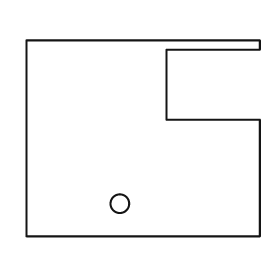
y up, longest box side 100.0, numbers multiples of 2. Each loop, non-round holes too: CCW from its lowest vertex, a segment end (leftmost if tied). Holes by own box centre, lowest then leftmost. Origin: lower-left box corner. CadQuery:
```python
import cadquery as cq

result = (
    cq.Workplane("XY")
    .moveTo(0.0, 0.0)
    .lineTo(100.0, 0.0)
    .lineTo(100.0, 50.0)
    .lineTo(60.0, 50.0)
    .lineTo(60.0, 80.0)
    .lineTo(100.0, 80.0)
    .lineTo(100.0, 84.0)
    .lineTo(0.0, 84.0)
    .close()
    .moveTo(40.0, 14.0)
    .circle(4.0)
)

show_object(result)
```